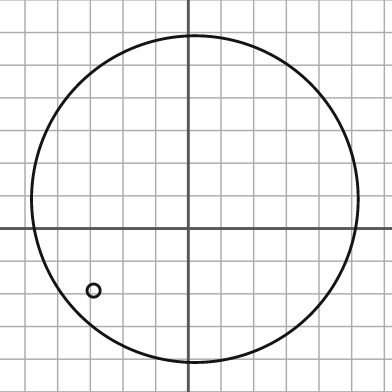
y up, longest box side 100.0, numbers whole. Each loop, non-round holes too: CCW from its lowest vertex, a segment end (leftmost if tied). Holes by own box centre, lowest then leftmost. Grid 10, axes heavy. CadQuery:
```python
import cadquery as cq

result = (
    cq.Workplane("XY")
    .moveTo(2.0, 9.0)
    .circle(50.0)
    .moveTo(-29.0, -19.0)
    .circle(2.0)
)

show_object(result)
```